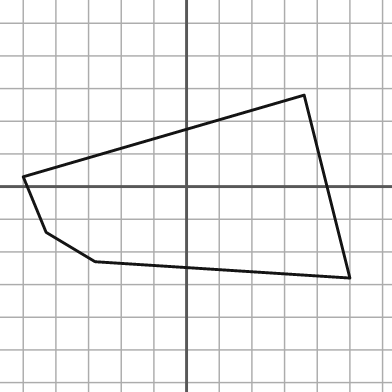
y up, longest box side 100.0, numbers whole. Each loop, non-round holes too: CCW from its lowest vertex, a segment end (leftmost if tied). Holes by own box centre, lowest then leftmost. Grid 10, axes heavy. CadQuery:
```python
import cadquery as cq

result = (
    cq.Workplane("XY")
    .moveTo(50.0, -28.0)
    .lineTo(36.0, 28.0)
    .lineTo(-50.0, 3.0)
    .lineTo(-43.0, -14.0)
    .lineTo(-28.0, -23.0)
    .close()
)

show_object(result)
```